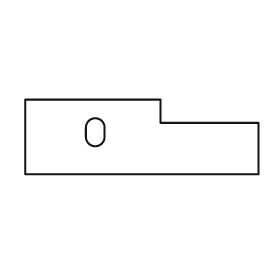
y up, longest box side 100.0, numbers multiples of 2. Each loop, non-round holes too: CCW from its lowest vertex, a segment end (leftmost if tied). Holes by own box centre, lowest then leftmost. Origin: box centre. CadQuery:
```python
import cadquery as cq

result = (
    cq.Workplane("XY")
    .moveTo(-50.0, -16.0)
    .lineTo(50.0, -16.0)
    .lineTo(50.0, 6.0)
    .lineTo(8.0, 6.0)
    .lineTo(8.0, 16.0)
    .lineTo(-50.0, 16.0)
    .close()
    .moveTo(-24.0, 0.0)
    .threePointArc((-20.0, -4.0), (-16.0, 0.0))
    .lineTo(-16.0, 4.0)
    .threePointArc((-20.0, 8.0), (-24.0, 4.0))
    .close()
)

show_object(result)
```